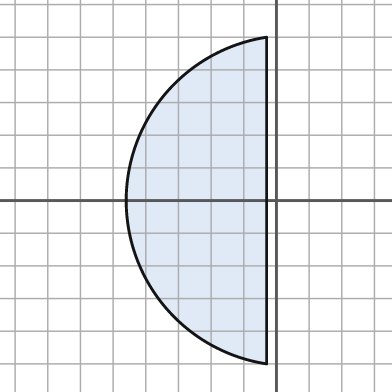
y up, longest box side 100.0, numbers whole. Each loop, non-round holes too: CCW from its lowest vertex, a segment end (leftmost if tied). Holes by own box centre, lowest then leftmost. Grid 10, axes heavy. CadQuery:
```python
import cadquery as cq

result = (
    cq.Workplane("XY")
    .moveTo(-3.0, -50.0)
    .lineTo(-3.0, 50.0)
    .threePointArc((-46.0, 0.0), (-3.0, -50.0))
    .close()
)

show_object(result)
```